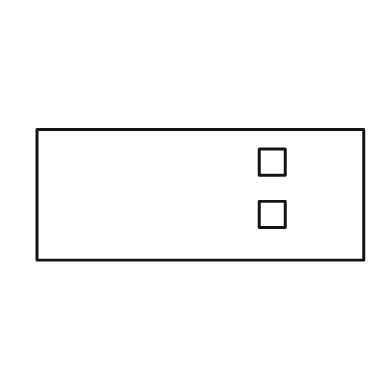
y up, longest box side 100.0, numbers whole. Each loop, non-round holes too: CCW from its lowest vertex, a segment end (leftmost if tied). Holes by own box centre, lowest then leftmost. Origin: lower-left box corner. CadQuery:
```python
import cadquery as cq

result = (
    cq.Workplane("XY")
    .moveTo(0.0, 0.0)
    .lineTo(100.0, 0.0)
    .lineTo(100.0, 40.0)
    .lineTo(0.0, 40.0)
    .close()
    .moveTo(68.0, 10.0)
    .lineTo(76.0, 10.0)
    .lineTo(76.0, 18.0)
    .lineTo(68.0, 18.0)
    .close()
    .moveTo(68.0, 26.0)
    .lineTo(76.0, 26.0)
    .lineTo(76.0, 34.0)
    .lineTo(68.0, 34.0)
    .close()
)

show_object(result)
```